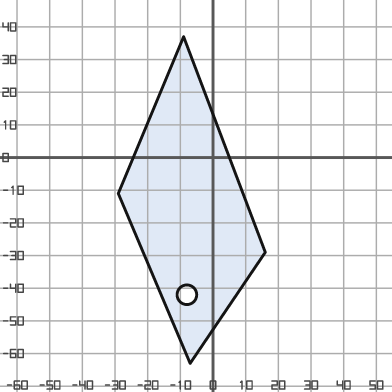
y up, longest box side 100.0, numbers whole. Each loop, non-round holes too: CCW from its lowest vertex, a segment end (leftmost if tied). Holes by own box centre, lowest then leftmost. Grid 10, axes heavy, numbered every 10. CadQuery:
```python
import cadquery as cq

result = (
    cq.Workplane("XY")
    .moveTo(-7.0, -63.0)
    .lineTo(16.0, -29.0)
    .lineTo(-9.0, 37.0)
    .lineTo(-29.0, -11.0)
    .close()
    .moveTo(-8.0, -42.0)
    .circle(3.0)
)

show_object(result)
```